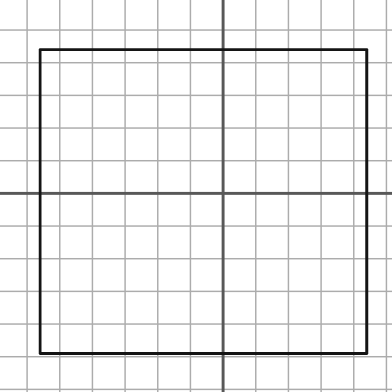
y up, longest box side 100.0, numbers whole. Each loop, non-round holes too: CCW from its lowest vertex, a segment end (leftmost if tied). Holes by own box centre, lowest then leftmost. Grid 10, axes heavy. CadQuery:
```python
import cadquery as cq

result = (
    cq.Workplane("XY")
    .moveTo(-56.0, -49.0)
    .lineTo(44.0, -49.0)
    .lineTo(44.0, 44.0)
    .lineTo(-56.0, 44.0)
    .close()
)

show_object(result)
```